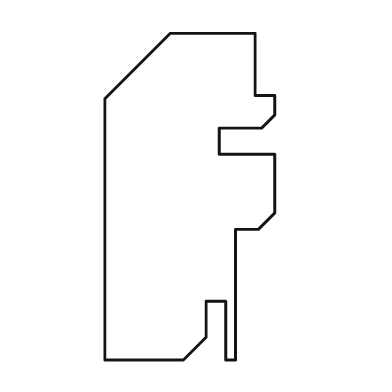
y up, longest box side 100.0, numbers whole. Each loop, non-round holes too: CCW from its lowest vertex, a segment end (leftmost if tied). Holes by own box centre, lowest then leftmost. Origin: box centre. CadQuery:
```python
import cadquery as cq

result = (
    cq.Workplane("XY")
    .moveTo(-26.0, -50.0)
    .lineTo(-2.0, -50.0)
    .lineTo(5.0, -43.0)
    .lineTo(5.0, -32.0)
    .lineTo(11.0, -32.0)
    .lineTo(11.0, -50.0)
    .lineTo(14.0, -50.0)
    .lineTo(14.0, -10.0)
    .lineTo(21.0, -10.0)
    .lineTo(26.0, -5.0)
    .lineTo(26.0, 13.0)
    .lineTo(9.0, 13.0)
    .lineTo(9.0, 21.0)
    .lineTo(22.0, 21.0)
    .lineTo(26.0, 25.0)
    .lineTo(26.0, 31.0)
    .lineTo(20.0, 31.0)
    .lineTo(20.0, 50.0)
    .lineTo(-6.0, 50.0)
    .lineTo(-26.0, 30.0)
    .close()
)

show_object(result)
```